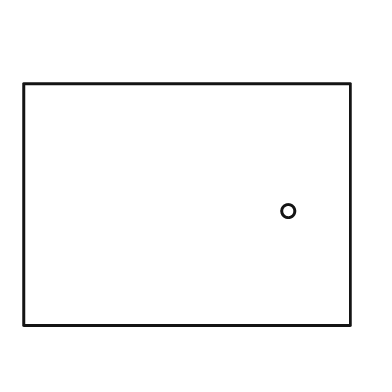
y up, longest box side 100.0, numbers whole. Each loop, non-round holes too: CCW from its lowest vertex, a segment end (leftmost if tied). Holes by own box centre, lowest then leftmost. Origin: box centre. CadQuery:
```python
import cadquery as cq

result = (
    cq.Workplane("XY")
    .moveTo(-50.0, -37.0)
    .lineTo(50.0, -37.0)
    .lineTo(50.0, 37.0)
    .lineTo(-50.0, 37.0)
    .close()
    .moveTo(31.0, -2.0)
    .circle(2.0)
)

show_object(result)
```